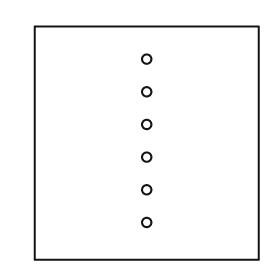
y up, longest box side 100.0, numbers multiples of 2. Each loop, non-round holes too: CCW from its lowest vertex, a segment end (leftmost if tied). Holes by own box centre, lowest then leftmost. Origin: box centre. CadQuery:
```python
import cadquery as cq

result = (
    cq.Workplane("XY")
    .moveTo(-48.0, -50.0)
    .lineTo(48.0, -50.0)
    .lineTo(48.0, 50.0)
    .lineTo(-48.0, 50.0)
    .close()
    .moveTo(0.0, -34.0)
    .circle(2.0)
    .moveTo(0.0, -20.0)
    .circle(2.0)
    .moveTo(0.0, -6.0)
    .circle(2.0)
    .moveTo(0.0, 8.0)
    .circle(2.0)
    .moveTo(0.0, 22.0)
    .circle(2.0)
    .moveTo(0.0, 36.0)
    .circle(2.0)
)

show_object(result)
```